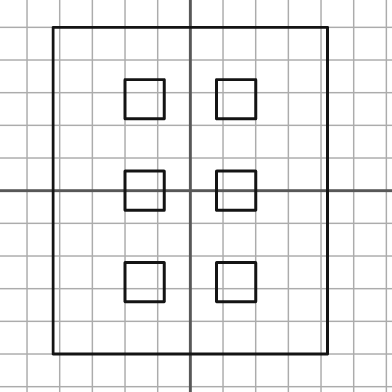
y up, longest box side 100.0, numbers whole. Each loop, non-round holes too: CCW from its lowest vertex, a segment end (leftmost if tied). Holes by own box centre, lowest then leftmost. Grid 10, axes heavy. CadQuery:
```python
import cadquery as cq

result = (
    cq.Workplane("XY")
    .moveTo(-42.0, -50.0)
    .lineTo(42.0, -50.0)
    .lineTo(42.0, 50.0)
    .lineTo(-42.0, 50.0)
    .close()
    .moveTo(-20.0, -34.0)
    .lineTo(-8.0, -34.0)
    .lineTo(-8.0, -22.0)
    .lineTo(-20.0, -22.0)
    .close()
    .moveTo(8.0, -34.0)
    .lineTo(20.0, -34.0)
    .lineTo(20.0, -22.0)
    .lineTo(8.0, -22.0)
    .close()
    .moveTo(-20.0, -6.0)
    .lineTo(-8.0, -6.0)
    .lineTo(-8.0, 6.0)
    .lineTo(-20.0, 6.0)
    .close()
    .moveTo(8.0, -6.0)
    .lineTo(20.0, -6.0)
    .lineTo(20.0, 6.0)
    .lineTo(8.0, 6.0)
    .close()
    .moveTo(-20.0, 22.0)
    .lineTo(-8.0, 22.0)
    .lineTo(-8.0, 34.0)
    .lineTo(-20.0, 34.0)
    .close()
    .moveTo(8.0, 22.0)
    .lineTo(20.0, 22.0)
    .lineTo(20.0, 34.0)
    .lineTo(8.0, 34.0)
    .close()
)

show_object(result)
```